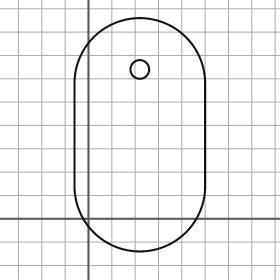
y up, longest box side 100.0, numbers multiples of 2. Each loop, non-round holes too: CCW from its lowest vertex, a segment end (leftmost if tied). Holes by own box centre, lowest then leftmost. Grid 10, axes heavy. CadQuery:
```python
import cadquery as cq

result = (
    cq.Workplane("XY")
    .moveTo(-6.0, 14.0)
    .threePointArc((22.0, -14.0), (50.0, 14.0))
    .lineTo(50.0, 58.0)
    .threePointArc((22.0, 86.0), (-6.0, 58.0))
    .close()
    .moveTo(22.0, 64.0)
    .circle(4.0)
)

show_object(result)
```